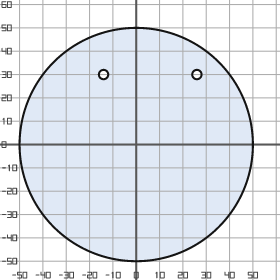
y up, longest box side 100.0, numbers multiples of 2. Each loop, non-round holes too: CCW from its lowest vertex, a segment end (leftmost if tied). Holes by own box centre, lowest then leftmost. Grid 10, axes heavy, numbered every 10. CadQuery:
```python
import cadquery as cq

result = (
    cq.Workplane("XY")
    .moveTo(0.0, 0.0)
    .circle(50.0)
    .moveTo(-14.0, 30.0)
    .circle(2.0)
    .moveTo(26.0, 30.0)
    .circle(2.0)
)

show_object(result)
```